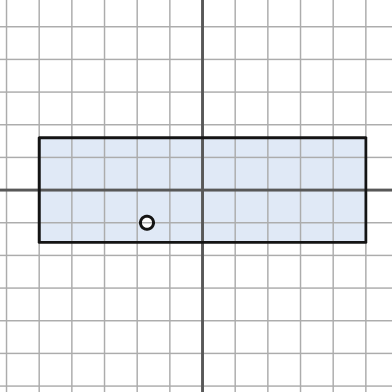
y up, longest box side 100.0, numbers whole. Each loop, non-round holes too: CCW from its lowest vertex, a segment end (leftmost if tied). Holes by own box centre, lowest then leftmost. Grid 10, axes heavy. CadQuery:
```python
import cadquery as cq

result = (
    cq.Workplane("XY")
    .moveTo(-50.0, -16.0)
    .lineTo(50.0, -16.0)
    .lineTo(50.0, 16.0)
    .lineTo(-50.0, 16.0)
    .close()
    .moveTo(-17.0, -10.0)
    .circle(2.0)
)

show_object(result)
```